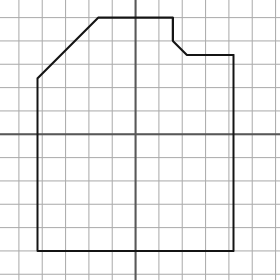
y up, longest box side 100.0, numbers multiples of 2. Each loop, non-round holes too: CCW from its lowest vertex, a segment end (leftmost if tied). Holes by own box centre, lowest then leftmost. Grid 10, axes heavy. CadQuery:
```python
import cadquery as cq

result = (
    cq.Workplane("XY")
    .moveTo(-42.0, -50.0)
    .lineTo(42.0, -50.0)
    .lineTo(42.0, 34.0)
    .lineTo(22.0, 34.0)
    .lineTo(16.0, 40.0)
    .lineTo(16.0, 50.0)
    .lineTo(-16.0, 50.0)
    .lineTo(-42.0, 24.0)
    .close()
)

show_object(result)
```